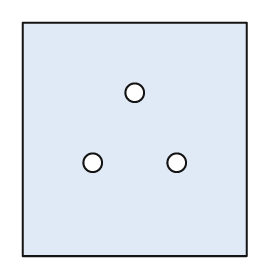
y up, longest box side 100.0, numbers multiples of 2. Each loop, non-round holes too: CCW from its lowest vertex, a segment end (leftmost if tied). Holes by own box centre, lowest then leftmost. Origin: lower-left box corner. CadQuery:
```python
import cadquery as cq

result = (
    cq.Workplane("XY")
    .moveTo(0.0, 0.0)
    .lineTo(96.0, 0.0)
    .lineTo(96.0, 100.0)
    .lineTo(0.0, 100.0)
    .close()
    .moveTo(30.0, 40.0)
    .circle(4.0)
    .moveTo(66.0, 40.0)
    .circle(4.0)
    .moveTo(48.0, 70.0)
    .circle(4.0)
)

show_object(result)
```